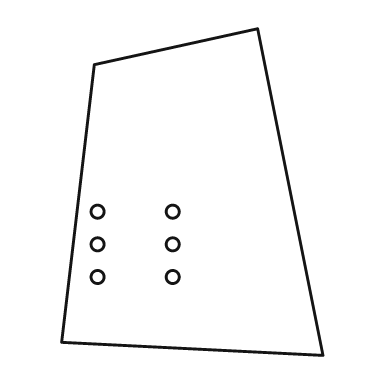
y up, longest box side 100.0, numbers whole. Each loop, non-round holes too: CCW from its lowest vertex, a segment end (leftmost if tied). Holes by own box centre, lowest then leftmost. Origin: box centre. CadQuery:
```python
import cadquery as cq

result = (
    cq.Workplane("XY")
    .moveTo(40.0, -50.0)
    .lineTo(20.0, 50.0)
    .lineTo(-30.0, 39.0)
    .lineTo(-40.0, -46.0)
    .close()
    .moveTo(-29.0, -26.0)
    .circle(2.0)
    .moveTo(-6.0, -26.0)
    .circle(2.0)
    .moveTo(-29.0, -16.0)
    .circle(2.0)
    .moveTo(-6.0, -16.0)
    .circle(2.0)
    .moveTo(-29.0, -6.0)
    .circle(2.0)
    .moveTo(-6.0, -6.0)
    .circle(2.0)
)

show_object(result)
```